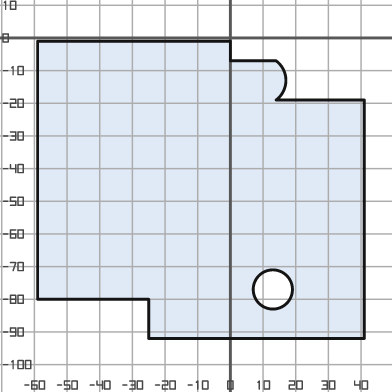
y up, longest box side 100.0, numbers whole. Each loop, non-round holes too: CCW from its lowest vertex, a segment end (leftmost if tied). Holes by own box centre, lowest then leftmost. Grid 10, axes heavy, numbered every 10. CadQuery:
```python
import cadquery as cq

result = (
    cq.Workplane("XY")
    .moveTo(-25.0, -92.0)
    .lineTo(41.0, -92.0)
    .lineTo(41.0, -19.0)
    .lineTo(14.0, -19.0)
    .threePointArc((17.0, -13.0), (14.0, -7.0))
    .lineTo(0.0, -7.0)
    .lineTo(0.0, -1.0)
    .lineTo(-59.0, -1.0)
    .lineTo(-59.0, -80.0)
    .lineTo(-25.0, -80.0)
    .close()
    .moveTo(13.0, -77.0)
    .circle(6.0)
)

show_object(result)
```